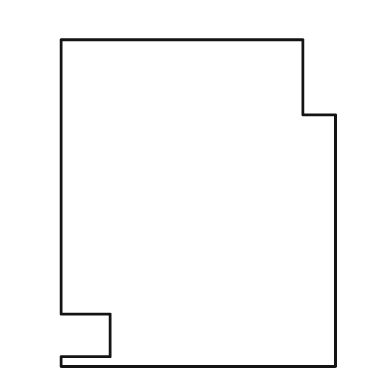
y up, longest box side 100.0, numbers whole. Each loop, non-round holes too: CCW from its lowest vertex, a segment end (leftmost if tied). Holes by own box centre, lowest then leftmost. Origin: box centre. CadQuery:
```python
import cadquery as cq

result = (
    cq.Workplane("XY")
    .moveTo(-42.0, -50.0)
    .lineTo(42.0, -50.0)
    .lineTo(42.0, 27.0)
    .lineTo(32.0, 27.0)
    .lineTo(32.0, 50.0)
    .lineTo(-42.0, 50.0)
    .lineTo(-42.0, -34.0)
    .lineTo(-27.0, -34.0)
    .lineTo(-27.0, -47.0)
    .lineTo(-42.0, -47.0)
    .close()
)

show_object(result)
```